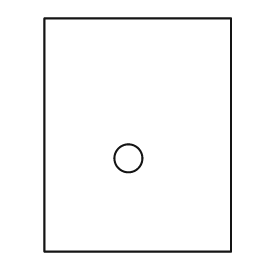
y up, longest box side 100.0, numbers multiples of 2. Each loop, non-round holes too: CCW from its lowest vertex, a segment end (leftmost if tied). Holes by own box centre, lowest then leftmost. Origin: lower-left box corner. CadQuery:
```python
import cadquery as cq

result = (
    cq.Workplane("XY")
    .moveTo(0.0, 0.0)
    .lineTo(80.0, 0.0)
    .lineTo(80.0, 100.0)
    .lineTo(0.0, 100.0)
    .close()
    .moveTo(36.0, 40.0)
    .circle(6.0)
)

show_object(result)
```